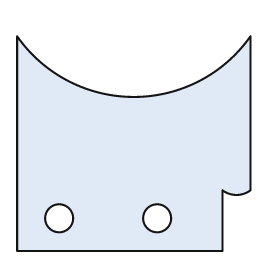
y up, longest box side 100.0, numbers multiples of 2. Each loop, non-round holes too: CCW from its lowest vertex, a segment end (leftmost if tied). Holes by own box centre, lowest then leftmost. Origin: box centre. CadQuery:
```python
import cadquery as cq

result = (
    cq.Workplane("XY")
    .moveTo(-50.0, -46.0)
    .lineTo(38.0, -46.0)
    .lineTo(38.0, -20.0)
    .threePointArc((44.0, -22.0), (50.0, -20.0))
    .lineTo(50.0, 46.0)
    .threePointArc((0.0, 20.0), (-50.0, 46.0))
    .close()
    .moveTo(-32.0, -32.0)
    .circle(6.0)
    .moveTo(10.0, -32.0)
    .circle(6.0)
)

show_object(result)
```